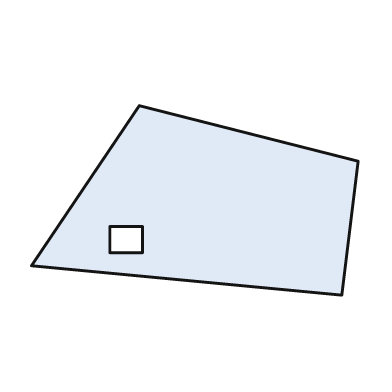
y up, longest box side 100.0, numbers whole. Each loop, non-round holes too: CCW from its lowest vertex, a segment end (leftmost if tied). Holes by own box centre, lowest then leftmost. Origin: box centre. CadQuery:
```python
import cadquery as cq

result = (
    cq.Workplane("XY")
    .moveTo(45.0, -29.0)
    .lineTo(50.0, 12.0)
    .lineTo(-17.0, 29.0)
    .lineTo(-50.0, -20.0)
    .close()
    .moveTo(-26.0, -16.0)
    .lineTo(-16.0, -16.0)
    .lineTo(-16.0, -8.0)
    .lineTo(-26.0, -8.0)
    .close()
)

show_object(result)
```